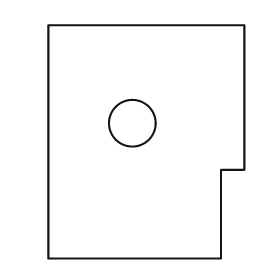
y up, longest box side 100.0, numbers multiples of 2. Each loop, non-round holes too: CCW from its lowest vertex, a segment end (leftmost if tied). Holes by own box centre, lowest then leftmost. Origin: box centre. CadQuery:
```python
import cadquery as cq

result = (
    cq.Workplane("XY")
    .moveTo(-42.0, -50.0)
    .lineTo(32.0, -50.0)
    .lineTo(32.0, -12.0)
    .lineTo(42.0, -12.0)
    .lineTo(42.0, 50.0)
    .lineTo(-42.0, 50.0)
    .close()
    .moveTo(-6.0, 8.0)
    .circle(10.0)
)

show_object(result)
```